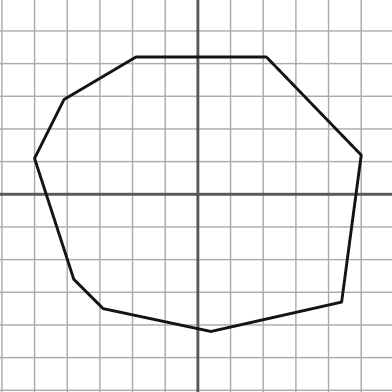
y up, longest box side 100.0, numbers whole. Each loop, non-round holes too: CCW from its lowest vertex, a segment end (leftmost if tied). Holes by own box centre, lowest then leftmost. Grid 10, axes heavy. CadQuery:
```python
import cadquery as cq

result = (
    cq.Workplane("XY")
    .moveTo(4.0, -42.0)
    .lineTo(44.0, -33.0)
    .lineTo(50.0, 12.0)
    .lineTo(21.0, 42.0)
    .lineTo(-19.0, 42.0)
    .lineTo(-41.0, 29.0)
    .lineTo(-50.0, 11.0)
    .lineTo(-38.0, -26.0)
    .lineTo(-29.0, -35.0)
    .close()
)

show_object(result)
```